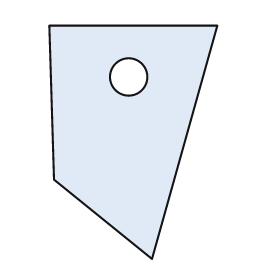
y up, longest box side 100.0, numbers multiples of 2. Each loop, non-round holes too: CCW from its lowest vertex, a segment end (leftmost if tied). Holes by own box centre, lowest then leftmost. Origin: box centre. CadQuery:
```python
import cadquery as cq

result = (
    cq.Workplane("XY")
    .moveTo(8.0, -50.0)
    .lineTo(36.0, 50.0)
    .lineTo(-36.0, 50.0)
    .lineTo(-34.0, -16.0)
    .close()
    .moveTo(-2.0, 28.0)
    .circle(8.0)
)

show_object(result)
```